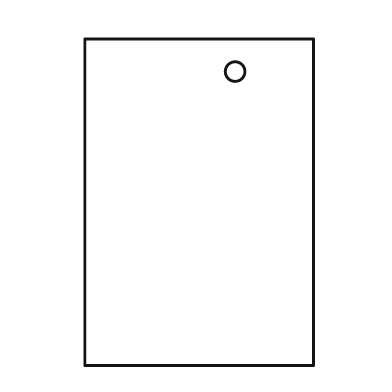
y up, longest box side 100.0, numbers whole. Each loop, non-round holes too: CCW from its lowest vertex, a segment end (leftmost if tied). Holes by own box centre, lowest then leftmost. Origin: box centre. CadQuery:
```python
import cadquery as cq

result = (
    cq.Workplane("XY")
    .moveTo(-35.0, -50.0)
    .lineTo(35.0, -50.0)
    .lineTo(35.0, 50.0)
    .lineTo(-35.0, 50.0)
    .close()
    .moveTo(11.0, 40.0)
    .circle(3.0)
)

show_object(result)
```